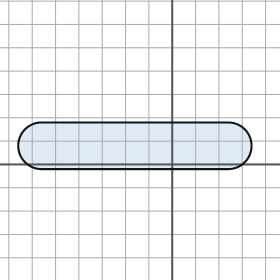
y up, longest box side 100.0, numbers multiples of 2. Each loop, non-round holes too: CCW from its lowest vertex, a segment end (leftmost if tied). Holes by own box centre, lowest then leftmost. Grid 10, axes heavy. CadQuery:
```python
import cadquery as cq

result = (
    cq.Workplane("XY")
    .moveTo(-56.0, -2.0)
    .lineTo(24.0, -2.0)
    .threePointArc((34.0, 8.0), (24.0, 18.0))
    .lineTo(-56.0, 18.0)
    .threePointArc((-66.0, 8.0), (-56.0, -2.0))
    .close()
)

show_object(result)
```